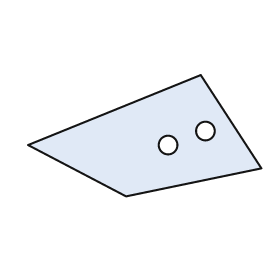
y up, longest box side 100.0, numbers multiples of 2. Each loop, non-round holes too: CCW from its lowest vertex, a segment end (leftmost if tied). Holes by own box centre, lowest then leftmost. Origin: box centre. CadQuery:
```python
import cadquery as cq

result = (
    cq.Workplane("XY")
    .moveTo(-8.0, -26.0)
    .lineTo(50.0, -14.0)
    .lineTo(24.0, 26.0)
    .lineTo(-50.0, -4.0)
    .close()
    .moveTo(10.0, -4.0)
    .circle(4.0)
    .moveTo(26.0, 2.0)
    .circle(4.0)
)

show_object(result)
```